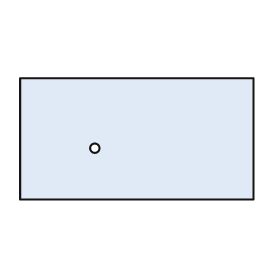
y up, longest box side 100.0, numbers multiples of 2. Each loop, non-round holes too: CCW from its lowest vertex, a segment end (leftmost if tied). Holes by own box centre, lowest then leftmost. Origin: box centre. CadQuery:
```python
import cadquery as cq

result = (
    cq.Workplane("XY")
    .moveTo(-50.0, -26.0)
    .lineTo(50.0, -26.0)
    .lineTo(50.0, 26.0)
    .lineTo(-50.0, 26.0)
    .close()
    .moveTo(-18.0, -4.0)
    .circle(2.0)
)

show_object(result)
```